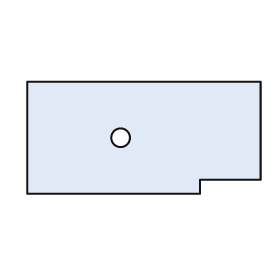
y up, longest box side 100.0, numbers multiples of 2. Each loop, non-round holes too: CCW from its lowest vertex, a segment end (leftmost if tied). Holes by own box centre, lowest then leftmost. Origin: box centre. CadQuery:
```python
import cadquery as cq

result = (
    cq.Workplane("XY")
    .moveTo(-50.0, -24.0)
    .lineTo(24.0, -24.0)
    .lineTo(24.0, -18.0)
    .lineTo(50.0, -18.0)
    .lineTo(50.0, 24.0)
    .lineTo(-50.0, 24.0)
    .close()
    .moveTo(-10.0, 0.0)
    .circle(4.0)
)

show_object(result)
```